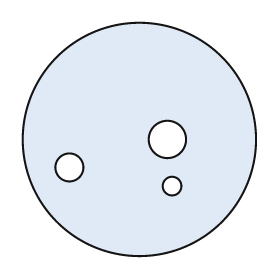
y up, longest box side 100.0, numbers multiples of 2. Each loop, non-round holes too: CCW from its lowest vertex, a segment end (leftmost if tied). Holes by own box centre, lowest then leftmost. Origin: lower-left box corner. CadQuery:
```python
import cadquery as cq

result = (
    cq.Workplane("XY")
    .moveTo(50.0, 50.0)
    .circle(50.0)
    .moveTo(64.0, 30.0)
    .circle(4.0)
    .moveTo(20.0, 38.0)
    .circle(6.0)
    .moveTo(62.0, 50.0)
    .circle(8.0)
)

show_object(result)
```